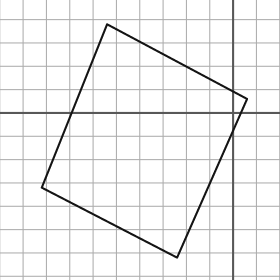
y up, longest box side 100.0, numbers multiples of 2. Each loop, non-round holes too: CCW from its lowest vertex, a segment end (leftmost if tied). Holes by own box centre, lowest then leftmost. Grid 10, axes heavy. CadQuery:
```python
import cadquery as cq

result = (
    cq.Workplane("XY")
    .moveTo(-24.0, -62.0)
    .lineTo(6.0, 6.0)
    .lineTo(-54.0, 38.0)
    .lineTo(-82.0, -32.0)
    .close()
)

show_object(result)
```